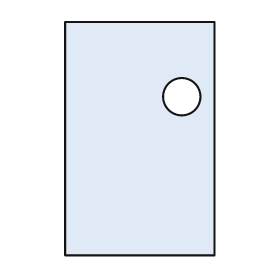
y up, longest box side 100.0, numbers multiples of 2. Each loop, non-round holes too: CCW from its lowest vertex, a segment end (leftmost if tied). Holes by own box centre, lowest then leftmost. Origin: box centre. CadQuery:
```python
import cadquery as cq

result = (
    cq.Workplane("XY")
    .moveTo(-32.0, -50.0)
    .lineTo(32.0, -50.0)
    .lineTo(32.0, 50.0)
    .lineTo(-32.0, 50.0)
    .close()
    .moveTo(18.0, 18.0)
    .circle(8.0)
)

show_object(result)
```